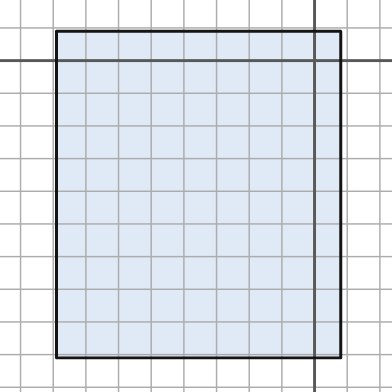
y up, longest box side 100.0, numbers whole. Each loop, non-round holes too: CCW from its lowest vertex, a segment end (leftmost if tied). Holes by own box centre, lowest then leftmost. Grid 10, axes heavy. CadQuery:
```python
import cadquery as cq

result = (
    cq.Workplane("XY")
    .moveTo(-79.0, -91.0)
    .lineTo(8.0, -91.0)
    .lineTo(8.0, 9.0)
    .lineTo(-79.0, 9.0)
    .close()
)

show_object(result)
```